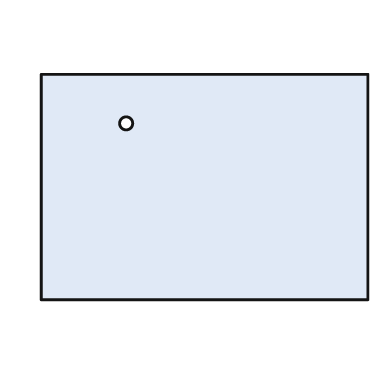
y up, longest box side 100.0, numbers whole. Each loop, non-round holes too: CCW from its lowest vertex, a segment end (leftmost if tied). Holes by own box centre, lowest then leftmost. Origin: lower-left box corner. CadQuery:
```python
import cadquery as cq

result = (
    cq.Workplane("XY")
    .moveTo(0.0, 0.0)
    .lineTo(100.0, 0.0)
    .lineTo(100.0, 69.0)
    .lineTo(0.0, 69.0)
    .close()
    .moveTo(26.0, 54.0)
    .circle(2.0)
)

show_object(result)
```